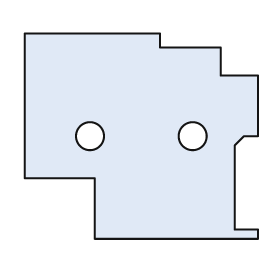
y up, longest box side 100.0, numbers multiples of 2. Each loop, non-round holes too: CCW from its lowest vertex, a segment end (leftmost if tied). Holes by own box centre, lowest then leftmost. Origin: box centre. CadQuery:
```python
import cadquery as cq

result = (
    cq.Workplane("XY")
    .moveTo(-20.0, -44.0)
    .lineTo(50.0, -44.0)
    .lineTo(50.0, -40.0)
    .lineTo(40.0, -40.0)
    .lineTo(40.0, -4.0)
    .lineTo(44.0, 0.0)
    .lineTo(50.0, 0.0)
    .lineTo(50.0, 26.0)
    .lineTo(34.0, 26.0)
    .lineTo(34.0, 38.0)
    .lineTo(8.0, 38.0)
    .lineTo(8.0, 44.0)
    .lineTo(-50.0, 44.0)
    .lineTo(-50.0, -18.0)
    .lineTo(-20.0, -18.0)
    .close()
    .moveTo(-22.0, 0.0)
    .circle(6.0)
    .moveTo(22.0, 0.0)
    .circle(6.0)
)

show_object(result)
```